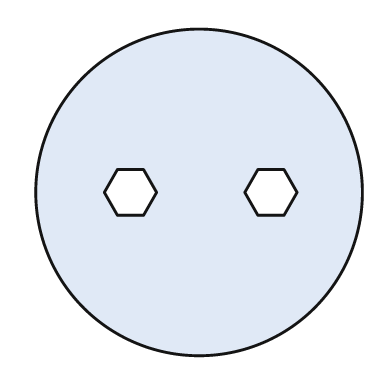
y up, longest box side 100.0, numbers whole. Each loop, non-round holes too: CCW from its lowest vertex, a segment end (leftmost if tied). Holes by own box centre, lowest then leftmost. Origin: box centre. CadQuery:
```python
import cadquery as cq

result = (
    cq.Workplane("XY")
    .moveTo(0.0, 0.0)
    .circle(50.0)
    .moveTo(-25.0, -7.0)
    .lineTo(-17.0, -7.0)
    .lineTo(-13.0, 0.0)
    .lineTo(-17.0, 7.0)
    .lineTo(-25.0, 7.0)
    .lineTo(-29.0, 0.0)
    .close()
    .moveTo(18.0, -7.0)
    .lineTo(26.0, -7.0)
    .lineTo(30.0, 0.0)
    .lineTo(26.0, 7.0)
    .lineTo(18.0, 7.0)
    .lineTo(14.0, 0.0)
    .close()
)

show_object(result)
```